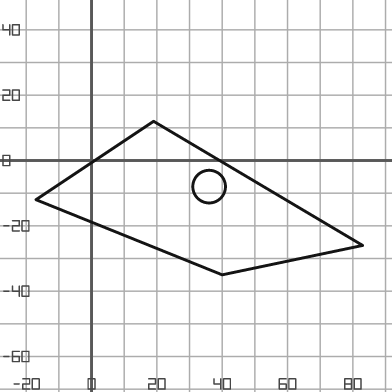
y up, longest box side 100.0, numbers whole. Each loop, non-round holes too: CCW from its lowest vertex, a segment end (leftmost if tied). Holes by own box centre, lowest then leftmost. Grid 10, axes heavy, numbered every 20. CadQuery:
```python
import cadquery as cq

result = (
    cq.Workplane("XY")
    .moveTo(40.0, -35.0)
    .lineTo(83.0, -26.0)
    .lineTo(19.0, 12.0)
    .lineTo(-17.0, -12.0)
    .close()
    .moveTo(36.0, -8.0)
    .circle(5.0)
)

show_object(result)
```